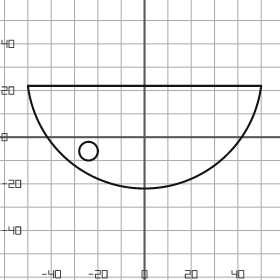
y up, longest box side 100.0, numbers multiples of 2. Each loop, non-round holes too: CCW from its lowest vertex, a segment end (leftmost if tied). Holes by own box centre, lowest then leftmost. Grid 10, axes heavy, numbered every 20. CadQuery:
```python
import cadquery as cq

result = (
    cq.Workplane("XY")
    .moveTo(-50.0, 22.0)
    .threePointArc((0.0, -22.0), (50.0, 22.0))
    .close()
    .moveTo(-24.0, -6.0)
    .circle(4.0)
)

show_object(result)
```